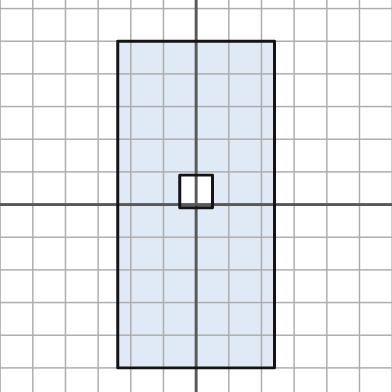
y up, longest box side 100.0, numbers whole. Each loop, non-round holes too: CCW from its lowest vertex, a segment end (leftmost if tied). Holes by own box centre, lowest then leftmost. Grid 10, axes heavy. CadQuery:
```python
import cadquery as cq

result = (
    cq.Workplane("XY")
    .moveTo(-24.0, -50.0)
    .lineTo(24.0, -50.0)
    .lineTo(24.0, 50.0)
    .lineTo(-24.0, 50.0)
    .close()
    .moveTo(-5.0, -1.0)
    .lineTo(5.0, -1.0)
    .lineTo(5.0, 9.0)
    .lineTo(-5.0, 9.0)
    .close()
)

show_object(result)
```